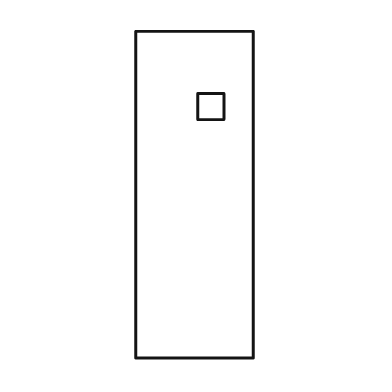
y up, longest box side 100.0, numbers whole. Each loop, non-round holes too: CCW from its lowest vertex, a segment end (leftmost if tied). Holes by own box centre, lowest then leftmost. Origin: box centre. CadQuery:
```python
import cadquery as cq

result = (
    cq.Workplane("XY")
    .moveTo(-18.0, -50.0)
    .lineTo(18.0, -50.0)
    .lineTo(18.0, 50.0)
    .lineTo(-18.0, 50.0)
    .close()
    .moveTo(1.0, 23.0)
    .lineTo(9.0, 23.0)
    .lineTo(9.0, 31.0)
    .lineTo(1.0, 31.0)
    .close()
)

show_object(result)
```